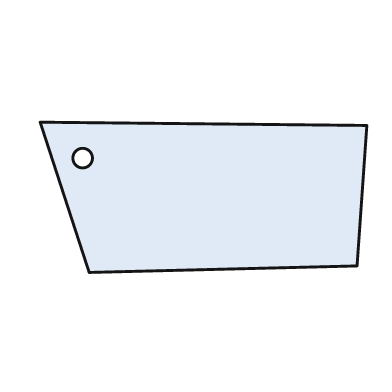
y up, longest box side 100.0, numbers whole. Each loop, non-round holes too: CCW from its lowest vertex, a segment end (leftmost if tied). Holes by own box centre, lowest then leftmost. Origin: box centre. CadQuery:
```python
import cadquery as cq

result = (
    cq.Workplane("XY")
    .moveTo(-35.0, -23.0)
    .lineTo(47.0, -21.0)
    .lineTo(50.0, 22.0)
    .lineTo(-50.0, 23.0)
    .close()
    .moveTo(-37.0, 12.0)
    .circle(3.0)
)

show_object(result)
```